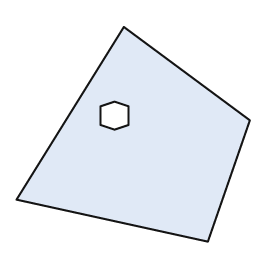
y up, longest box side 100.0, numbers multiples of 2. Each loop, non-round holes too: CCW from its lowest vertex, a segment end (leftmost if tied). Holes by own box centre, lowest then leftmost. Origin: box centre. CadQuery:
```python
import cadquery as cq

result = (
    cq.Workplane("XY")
    .moveTo(32.0, -46.0)
    .lineTo(50.0, 6.0)
    .lineTo(-4.0, 46.0)
    .lineTo(-50.0, -28.0)
    .close()
    .moveTo(-8.0, 2.0)
    .lineTo(-2.0, 4.0)
    .lineTo(-2.0, 12.0)
    .lineTo(-8.0, 14.0)
    .lineTo(-14.0, 12.0)
    .lineTo(-14.0, 4.0)
    .close()
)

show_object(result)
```